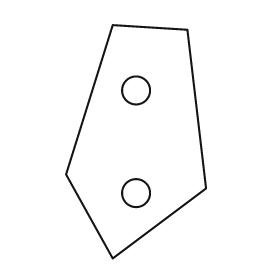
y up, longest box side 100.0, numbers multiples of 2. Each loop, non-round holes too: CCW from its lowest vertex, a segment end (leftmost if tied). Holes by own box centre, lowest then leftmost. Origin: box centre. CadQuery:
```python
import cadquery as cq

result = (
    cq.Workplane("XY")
    .moveTo(-10.0, -50.0)
    .lineTo(30.0, -20.0)
    .lineTo(22.0, 48.0)
    .lineTo(-10.0, 50.0)
    .lineTo(-30.0, -14.0)
    .close()
    .moveTo(0.0, -22.0)
    .circle(6.0)
    .moveTo(0.0, 22.0)
    .circle(6.0)
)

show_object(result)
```